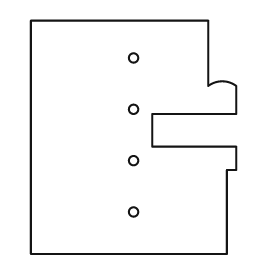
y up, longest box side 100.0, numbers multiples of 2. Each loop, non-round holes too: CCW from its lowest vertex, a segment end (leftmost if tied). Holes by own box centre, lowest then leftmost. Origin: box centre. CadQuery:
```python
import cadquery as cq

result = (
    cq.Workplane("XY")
    .moveTo(-44.0, -50.0)
    .lineTo(40.0, -50.0)
    .lineTo(40.0, -14.0)
    .lineTo(44.0, -14.0)
    .lineTo(44.0, -4.0)
    .lineTo(8.0, -4.0)
    .lineTo(8.0, 10.0)
    .lineTo(44.0, 10.0)
    .lineTo(44.0, 22.0)
    .threePointArc((38.0, 24.0), (32.0, 22.0))
    .lineTo(32.0, 50.0)
    .lineTo(-44.0, 50.0)
    .close()
    .moveTo(0.0, -32.0)
    .circle(2.0)
    .moveTo(0.0, -10.0)
    .circle(2.0)
    .moveTo(0.0, 12.0)
    .circle(2.0)
    .moveTo(0.0, 34.0)
    .circle(2.0)
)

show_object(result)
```